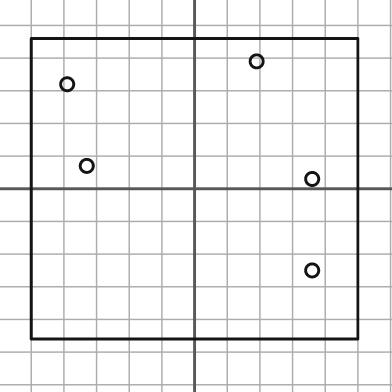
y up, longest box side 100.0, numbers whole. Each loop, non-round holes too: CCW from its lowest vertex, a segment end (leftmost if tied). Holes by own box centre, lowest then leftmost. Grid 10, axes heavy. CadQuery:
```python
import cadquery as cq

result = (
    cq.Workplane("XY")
    .moveTo(-50.0, -46.0)
    .lineTo(50.0, -46.0)
    .lineTo(50.0, 46.0)
    .lineTo(-50.0, 46.0)
    .close()
    .moveTo(36.0, -25.0)
    .circle(2.0)
    .moveTo(36.0, 3.0)
    .circle(2.0)
    .moveTo(-33.0, 7.0)
    .circle(2.0)
    .moveTo(-39.0, 32.0)
    .circle(2.0)
    .moveTo(19.0, 39.0)
    .circle(2.0)
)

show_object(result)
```